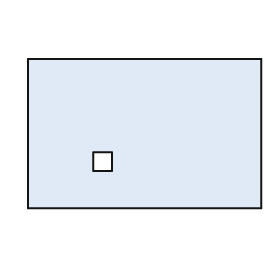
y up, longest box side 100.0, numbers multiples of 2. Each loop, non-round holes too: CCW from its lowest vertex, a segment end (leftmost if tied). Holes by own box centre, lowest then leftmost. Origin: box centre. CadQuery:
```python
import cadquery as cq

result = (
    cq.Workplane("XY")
    .moveTo(-50.0, -32.0)
    .lineTo(50.0, -32.0)
    .lineTo(50.0, 32.0)
    .lineTo(-50.0, 32.0)
    .close()
    .moveTo(-22.0, -16.0)
    .lineTo(-14.0, -16.0)
    .lineTo(-14.0, -8.0)
    .lineTo(-22.0, -8.0)
    .close()
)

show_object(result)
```